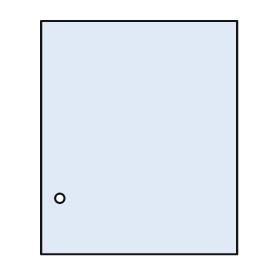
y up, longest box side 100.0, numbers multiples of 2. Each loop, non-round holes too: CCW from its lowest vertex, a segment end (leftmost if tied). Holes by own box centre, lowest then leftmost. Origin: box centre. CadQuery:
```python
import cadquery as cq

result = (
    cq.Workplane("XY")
    .moveTo(-42.0, -50.0)
    .lineTo(42.0, -50.0)
    .lineTo(42.0, 50.0)
    .lineTo(-42.0, 50.0)
    .close()
    .moveTo(-34.0, -26.0)
    .circle(2.0)
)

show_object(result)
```